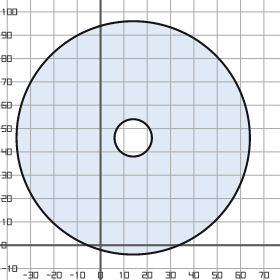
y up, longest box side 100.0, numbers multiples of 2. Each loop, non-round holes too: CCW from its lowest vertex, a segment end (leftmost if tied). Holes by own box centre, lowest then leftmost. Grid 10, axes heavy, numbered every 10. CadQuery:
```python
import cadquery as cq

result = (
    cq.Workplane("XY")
    .moveTo(14.0, 46.0)
    .circle(50.0)
    .moveTo(14.0, 46.0)
    .circle(8.0)
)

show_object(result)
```